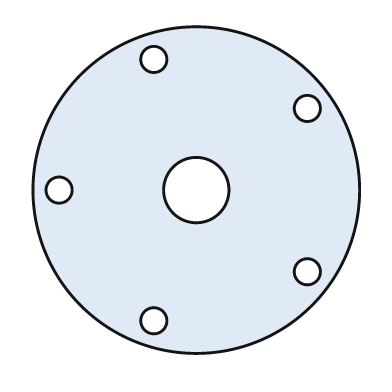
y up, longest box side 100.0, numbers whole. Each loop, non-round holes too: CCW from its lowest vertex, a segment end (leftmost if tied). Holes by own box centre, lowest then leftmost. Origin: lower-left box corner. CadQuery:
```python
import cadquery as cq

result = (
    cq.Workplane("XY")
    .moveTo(50.0, 50.0)
    .circle(50.0)
    .moveTo(37.0, 10.0)
    .circle(4.0)
    .moveTo(84.0, 25.0)
    .circle(4.0)
    .moveTo(8.0, 50.0)
    .circle(4.0)
    .moveTo(50.0, 50.0)
    .circle(10.0)
    .moveTo(84.0, 75.0)
    .circle(4.0)
    .moveTo(37.0, 90.0)
    .circle(4.0)
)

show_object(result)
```